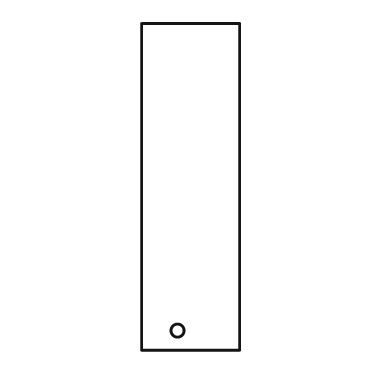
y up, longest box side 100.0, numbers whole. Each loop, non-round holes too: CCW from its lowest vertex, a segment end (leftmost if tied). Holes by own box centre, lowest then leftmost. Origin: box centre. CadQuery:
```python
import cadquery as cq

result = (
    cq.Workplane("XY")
    .moveTo(-15.0, -50.0)
    .lineTo(15.0, -50.0)
    .lineTo(15.0, 50.0)
    .lineTo(-15.0, 50.0)
    .close()
    .moveTo(-4.0, -44.0)
    .circle(2.0)
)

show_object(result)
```